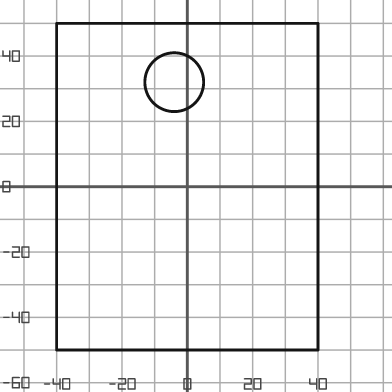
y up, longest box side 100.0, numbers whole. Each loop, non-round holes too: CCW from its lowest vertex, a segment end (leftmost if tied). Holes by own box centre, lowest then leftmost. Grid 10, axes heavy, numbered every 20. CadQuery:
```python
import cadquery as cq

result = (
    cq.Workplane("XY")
    .moveTo(-40.0, -50.0)
    .lineTo(40.0, -50.0)
    .lineTo(40.0, 50.0)
    .lineTo(-40.0, 50.0)
    .close()
    .moveTo(-4.0, 32.0)
    .circle(9.0)
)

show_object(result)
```